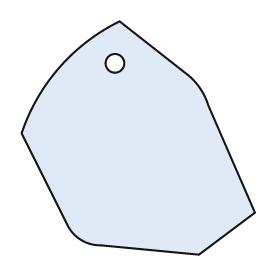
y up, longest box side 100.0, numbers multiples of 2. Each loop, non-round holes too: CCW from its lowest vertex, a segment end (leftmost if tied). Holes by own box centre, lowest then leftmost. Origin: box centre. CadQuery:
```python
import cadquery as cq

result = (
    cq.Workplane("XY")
    .moveTo(26.0, -50.0)
    .lineTo(50.0, -32.0)
    .lineTo(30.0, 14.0)
    .threePointArc((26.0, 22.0), (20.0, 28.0))
    .lineTo(-8.0, 50.0)
    .threePointArc((-34.0, 30.0), (-50.0, 2.0))
    .lineTo(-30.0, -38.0)
    .threePointArc((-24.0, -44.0), (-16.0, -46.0))
    .close()
    .moveTo(-10.0, 32.0)
    .circle(4.0)
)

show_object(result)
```